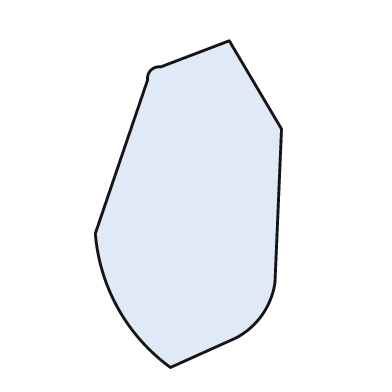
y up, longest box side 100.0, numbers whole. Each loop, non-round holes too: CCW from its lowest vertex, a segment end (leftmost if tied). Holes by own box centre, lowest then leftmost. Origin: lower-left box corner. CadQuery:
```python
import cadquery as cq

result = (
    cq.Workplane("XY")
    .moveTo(23.0, 0.0)
    .lineTo(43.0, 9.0)
    .threePointArc((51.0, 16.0), (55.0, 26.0))
    .lineTo(57.0, 73.0)
    .lineTo(41.0, 100.0)
    .lineTo(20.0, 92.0)
    .threePointArc((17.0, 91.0), (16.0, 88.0))
    .lineTo(0.0, 41.0)
    .threePointArc((7.0, 18.0), (23.0, 0.0))
    .close()
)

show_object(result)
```